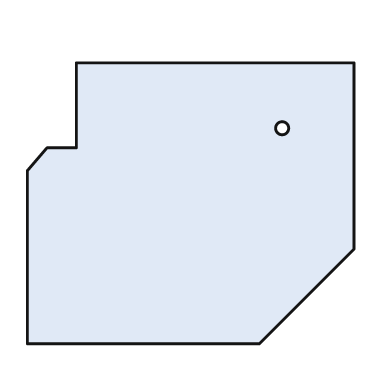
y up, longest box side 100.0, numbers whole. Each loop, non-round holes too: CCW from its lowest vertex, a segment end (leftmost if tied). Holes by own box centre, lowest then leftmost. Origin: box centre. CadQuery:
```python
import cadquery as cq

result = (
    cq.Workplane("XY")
    .moveTo(-50.0, -43.0)
    .lineTo(21.0, -43.0)
    .lineTo(50.0, -14.0)
    .lineTo(50.0, 43.0)
    .lineTo(-35.0, 43.0)
    .lineTo(-35.0, 17.0)
    .lineTo(-44.0, 17.0)
    .lineTo(-50.0, 10.0)
    .close()
    .moveTo(28.0, 23.0)
    .circle(2.0)
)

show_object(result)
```